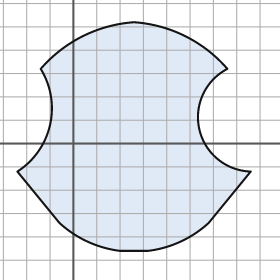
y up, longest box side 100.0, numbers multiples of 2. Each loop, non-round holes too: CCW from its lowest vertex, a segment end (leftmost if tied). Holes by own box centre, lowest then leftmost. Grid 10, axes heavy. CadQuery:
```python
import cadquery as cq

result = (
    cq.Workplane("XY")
    .moveTo(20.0, -46.0)
    .lineTo(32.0, -46.0)
    .threePointArc((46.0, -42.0), (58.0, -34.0))
    .lineTo(76.0, -12.0)
    .threePointArc((54.0, 6.0), (66.0, 32.0))
    .threePointArc((48.0, 46.0), (26.0, 52.0))
    .threePointArc((4.0, 46.0), (-14.0, 32.0))
    .threePointArc((-10.0, 8.0), (-24.0, -12.0))
    .lineTo(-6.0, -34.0)
    .threePointArc((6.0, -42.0), (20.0, -46.0))
    .close()
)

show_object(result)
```